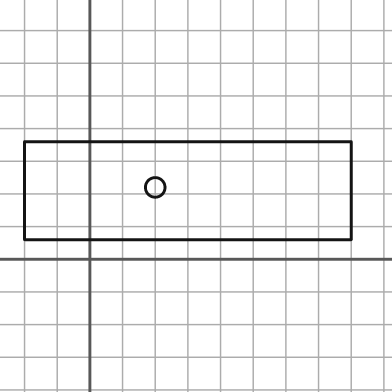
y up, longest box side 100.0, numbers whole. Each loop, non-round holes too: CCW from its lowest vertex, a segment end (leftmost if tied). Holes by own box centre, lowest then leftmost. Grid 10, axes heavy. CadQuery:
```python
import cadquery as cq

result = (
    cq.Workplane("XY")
    .moveTo(-20.0, 6.0)
    .lineTo(80.0, 6.0)
    .lineTo(80.0, 36.0)
    .lineTo(-20.0, 36.0)
    .close()
    .moveTo(20.0, 22.0)
    .circle(3.0)
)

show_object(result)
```